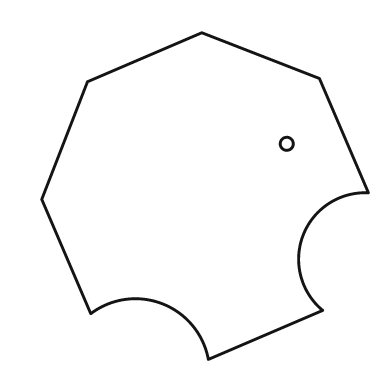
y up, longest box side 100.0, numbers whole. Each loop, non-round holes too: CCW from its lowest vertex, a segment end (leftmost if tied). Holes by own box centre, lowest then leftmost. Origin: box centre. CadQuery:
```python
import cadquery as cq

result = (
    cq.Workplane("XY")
    .moveTo(1.0, -50.0)
    .lineTo(36.0, -35.0)
    .threePointArc((30.0, -12.0), (50.0, 1.0))
    .lineTo(35.0, 36.0)
    .lineTo(-1.0, 50.0)
    .lineTo(-36.0, 35.0)
    .lineTo(-50.0, -1.0)
    .lineTo(-35.0, -36.0)
    .threePointArc((-13.0, -33.0), (1.0, -50.0))
    .close()
    .moveTo(25.0, 16.0)
    .circle(2.0)
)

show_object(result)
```